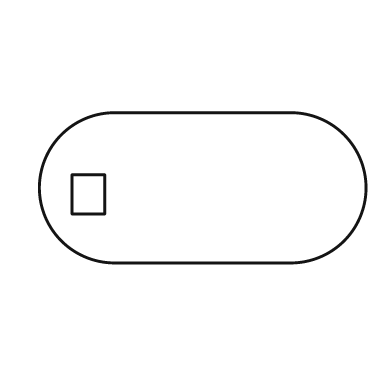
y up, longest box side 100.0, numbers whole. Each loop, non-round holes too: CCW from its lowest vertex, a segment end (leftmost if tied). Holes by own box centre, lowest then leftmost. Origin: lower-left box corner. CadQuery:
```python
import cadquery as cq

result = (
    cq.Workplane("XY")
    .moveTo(23.0, 0.0)
    .lineTo(77.0, 0.0)
    .threePointArc((100.0, 23.0), (77.0, 46.0))
    .lineTo(23.0, 46.0)
    .threePointArc((0.0, 23.0), (23.0, 0.0))
    .close()
    .moveTo(10.0, 15.0)
    .lineTo(20.0, 15.0)
    .lineTo(20.0, 27.0)
    .lineTo(10.0, 27.0)
    .close()
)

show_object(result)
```